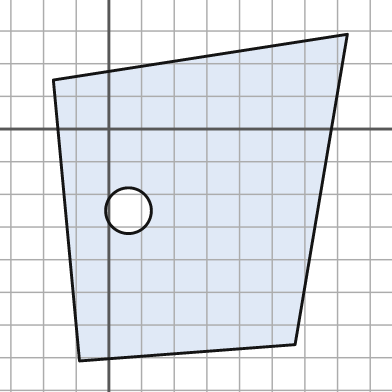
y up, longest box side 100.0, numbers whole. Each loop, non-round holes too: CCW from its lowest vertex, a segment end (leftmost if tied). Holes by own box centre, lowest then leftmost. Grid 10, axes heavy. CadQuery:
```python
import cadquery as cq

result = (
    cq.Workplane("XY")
    .moveTo(-9.0, -71.0)
    .lineTo(57.0, -66.0)
    .lineTo(73.0, 29.0)
    .lineTo(-17.0, 15.0)
    .close()
    .moveTo(6.0, -25.0)
    .circle(7.0)
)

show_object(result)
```